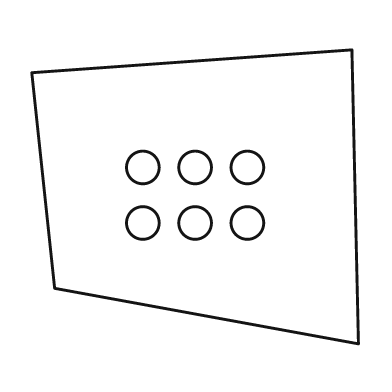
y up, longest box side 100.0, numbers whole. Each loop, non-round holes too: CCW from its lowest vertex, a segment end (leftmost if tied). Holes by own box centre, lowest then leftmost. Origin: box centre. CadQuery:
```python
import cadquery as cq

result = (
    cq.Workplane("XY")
    .moveTo(50.0, -45.0)
    .lineTo(48.0, 45.0)
    .lineTo(-50.0, 38.0)
    .lineTo(-43.0, -28.0)
    .close()
    .moveTo(-16.0, -8.0)
    .circle(5.0)
    .moveTo(0.0, -8.0)
    .circle(5.0)
    .moveTo(16.0, -8.0)
    .circle(5.0)
    .moveTo(-16.0, 9.0)
    .circle(5.0)
    .moveTo(0.0, 9.0)
    .circle(5.0)
    .moveTo(16.0, 9.0)
    .circle(5.0)
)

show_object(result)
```